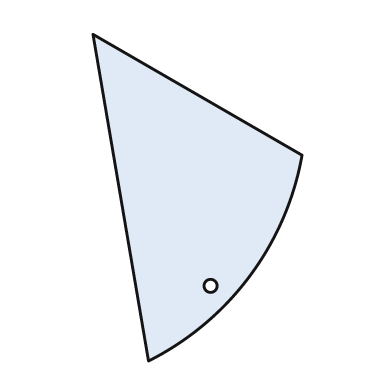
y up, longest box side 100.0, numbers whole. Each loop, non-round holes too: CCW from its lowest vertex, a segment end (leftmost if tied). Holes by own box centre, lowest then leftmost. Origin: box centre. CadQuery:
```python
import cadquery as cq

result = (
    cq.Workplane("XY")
    .moveTo(-15.0, -50.0)
    .threePointArc((16.0, -24.0), (32.0, 13.0))
    .lineTo(-32.0, 50.0)
    .close()
    .moveTo(4.0, -27.0)
    .circle(2.0)
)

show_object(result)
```